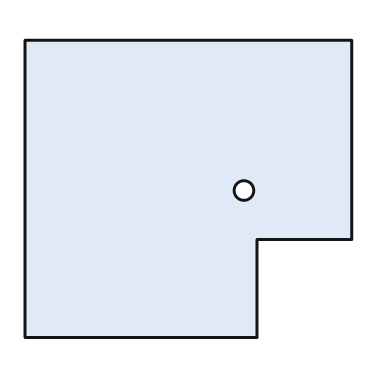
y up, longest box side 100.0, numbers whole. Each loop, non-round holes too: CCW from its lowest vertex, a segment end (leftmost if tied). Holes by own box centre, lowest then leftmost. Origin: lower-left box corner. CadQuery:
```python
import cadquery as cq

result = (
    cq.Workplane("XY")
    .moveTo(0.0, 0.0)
    .lineTo(71.0, 0.0)
    .lineTo(71.0, 30.0)
    .lineTo(100.0, 30.0)
    .lineTo(100.0, 91.0)
    .lineTo(0.0, 91.0)
    .close()
    .moveTo(67.0, 45.0)
    .circle(3.0)
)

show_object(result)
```